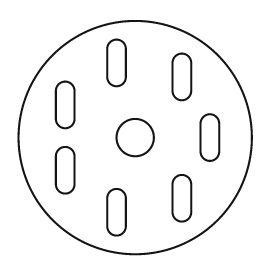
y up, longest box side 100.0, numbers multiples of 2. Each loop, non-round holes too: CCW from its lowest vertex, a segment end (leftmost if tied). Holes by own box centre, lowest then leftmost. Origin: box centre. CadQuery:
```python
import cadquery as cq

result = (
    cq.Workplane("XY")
    .moveTo(0.0, 0.0)
    .circle(50.0)
    .moveTo(-12.0, -38.0)
    .threePointArc((-8.0, -42.0), (-4.0, -38.0))
    .lineTo(-4.0, -26.0)
    .threePointArc((-8.0, -22.0), (-12.0, -26.0))
    .close()
    .moveTo(16.0, -32.0)
    .threePointArc((20.0, -36.0), (24.0, -32.0))
    .lineTo(24.0, -20.0)
    .threePointArc((20.0, -16.0), (16.0, -20.0))
    .close()
    .moveTo(-34.0, -20.0)
    .threePointArc((-30.0, -24.0), (-26.0, -20.0))
    .lineTo(-26.0, -8.0)
    .threePointArc((-30.0, -4.0), (-34.0, -8.0))
    .close()
    .moveTo(0.0, 0.0)
    .circle(8.0)
    .moveTo(28.0, -6.0)
    .threePointArc((32.0, -10.0), (36.0, -6.0))
    .lineTo(36.0, 6.0)
    .threePointArc((32.0, 10.0), (28.0, 6.0))
    .close()
    .moveTo(-34.0, 8.0)
    .threePointArc((-30.0, 4.0), (-26.0, 8.0))
    .lineTo(-26.0, 20.0)
    .threePointArc((-30.0, 24.0), (-34.0, 20.0))
    .close()
    .moveTo(16.0, 20.0)
    .threePointArc((20.0, 16.0), (24.0, 20.0))
    .lineTo(24.0, 32.0)
    .threePointArc((20.0, 36.0), (16.0, 32.0))
    .close()
    .moveTo(-12.0, 26.0)
    .threePointArc((-8.0, 22.0), (-4.0, 26.0))
    .lineTo(-4.0, 38.0)
    .threePointArc((-8.0, 42.0), (-12.0, 38.0))
    .close()
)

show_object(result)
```